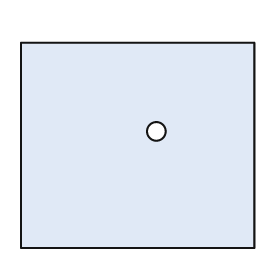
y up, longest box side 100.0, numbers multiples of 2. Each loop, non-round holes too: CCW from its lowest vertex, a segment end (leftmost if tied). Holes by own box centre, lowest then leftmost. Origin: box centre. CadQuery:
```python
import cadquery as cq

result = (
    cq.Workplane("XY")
    .moveTo(-50.0, -44.0)
    .lineTo(50.0, -44.0)
    .lineTo(50.0, 44.0)
    .lineTo(-50.0, 44.0)
    .close()
    .moveTo(8.0, 6.0)
    .circle(4.0)
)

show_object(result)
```